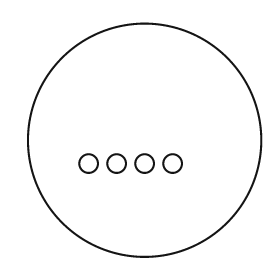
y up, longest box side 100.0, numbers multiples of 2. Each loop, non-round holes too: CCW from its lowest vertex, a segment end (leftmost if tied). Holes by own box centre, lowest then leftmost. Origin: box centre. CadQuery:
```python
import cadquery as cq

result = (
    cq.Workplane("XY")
    .moveTo(0.0, 0.0)
    .circle(50.0)
    .moveTo(-24.0, -10.0)
    .circle(4.0)
    .moveTo(-12.0, -10.0)
    .circle(4.0)
    .moveTo(0.0, -10.0)
    .circle(4.0)
    .moveTo(12.0, -10.0)
    .circle(4.0)
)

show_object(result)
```